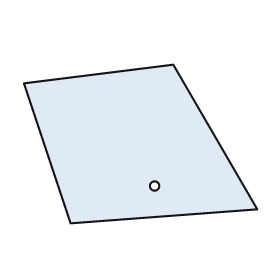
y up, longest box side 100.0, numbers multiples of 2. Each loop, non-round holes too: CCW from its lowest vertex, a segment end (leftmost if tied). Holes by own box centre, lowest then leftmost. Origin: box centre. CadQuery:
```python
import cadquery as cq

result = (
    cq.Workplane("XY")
    .moveTo(-30.0, -34.0)
    .lineTo(50.0, -28.0)
    .lineTo(14.0, 34.0)
    .lineTo(-50.0, 26.0)
    .close()
    .moveTo(6.0, -18.0)
    .circle(2.0)
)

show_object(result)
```